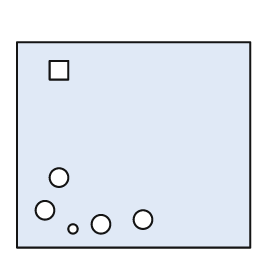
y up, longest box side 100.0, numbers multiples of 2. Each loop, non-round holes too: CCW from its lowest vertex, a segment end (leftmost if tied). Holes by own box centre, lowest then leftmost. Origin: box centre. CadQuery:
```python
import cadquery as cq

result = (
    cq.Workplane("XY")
    .moveTo(-50.0, -44.0)
    .lineTo(50.0, -44.0)
    .lineTo(50.0, 44.0)
    .lineTo(-50.0, 44.0)
    .close()
    .moveTo(-26.0, -36.0)
    .circle(2.0)
    .moveTo(-14.0, -34.0)
    .circle(4.0)
    .moveTo(4.0, -32.0)
    .circle(4.0)
    .moveTo(-38.0, -28.0)
    .circle(4.0)
    .moveTo(-32.0, -14.0)
    .circle(4.0)
    .moveTo(-36.0, 28.0)
    .lineTo(-28.0, 28.0)
    .lineTo(-28.0, 36.0)
    .lineTo(-36.0, 36.0)
    .close()
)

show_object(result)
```